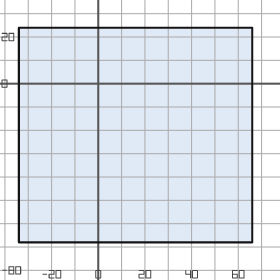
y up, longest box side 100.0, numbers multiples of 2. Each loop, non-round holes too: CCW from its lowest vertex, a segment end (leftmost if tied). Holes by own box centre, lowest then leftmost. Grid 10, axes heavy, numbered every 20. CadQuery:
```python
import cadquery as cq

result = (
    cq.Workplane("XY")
    .moveTo(-34.0, -68.0)
    .lineTo(66.0, -68.0)
    .lineTo(66.0, 24.0)
    .lineTo(-34.0, 24.0)
    .close()
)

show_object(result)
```